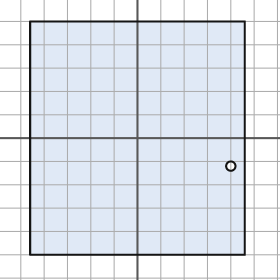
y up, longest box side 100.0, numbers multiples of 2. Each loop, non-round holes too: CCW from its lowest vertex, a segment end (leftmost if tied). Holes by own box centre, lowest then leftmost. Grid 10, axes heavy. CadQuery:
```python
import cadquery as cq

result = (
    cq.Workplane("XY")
    .moveTo(-46.0, -50.0)
    .lineTo(46.0, -50.0)
    .lineTo(46.0, 50.0)
    .lineTo(-46.0, 50.0)
    .close()
    .moveTo(40.0, -12.0)
    .circle(2.0)
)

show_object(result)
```